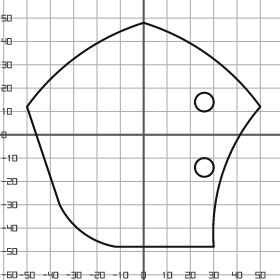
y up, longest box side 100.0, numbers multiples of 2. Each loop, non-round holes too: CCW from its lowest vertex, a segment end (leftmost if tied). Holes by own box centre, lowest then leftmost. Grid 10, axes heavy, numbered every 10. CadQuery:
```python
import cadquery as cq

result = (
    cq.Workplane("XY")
    .moveTo(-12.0, -48.0)
    .lineTo(30.0, -48.0)
    .threePointArc((34.0, -16.0), (50.0, 12.0))
    .threePointArc((28.0, 34.0), (0.0, 48.0))
    .threePointArc((-28.0, 34.0), (-50.0, 12.0))
    .lineTo(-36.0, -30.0)
    .threePointArc((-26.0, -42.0), (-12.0, -48.0))
    .close()
    .moveTo(26.0, -14.0)
    .circle(4.0)
    .moveTo(26.0, 14.0)
    .circle(4.0)
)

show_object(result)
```